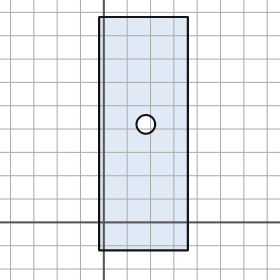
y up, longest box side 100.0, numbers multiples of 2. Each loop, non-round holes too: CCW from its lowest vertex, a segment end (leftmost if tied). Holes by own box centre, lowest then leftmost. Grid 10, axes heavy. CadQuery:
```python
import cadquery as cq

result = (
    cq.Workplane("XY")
    .moveTo(-2.0, -12.0)
    .lineTo(36.0, -12.0)
    .lineTo(36.0, 88.0)
    .lineTo(-2.0, 88.0)
    .close()
    .moveTo(18.0, 42.0)
    .circle(4.0)
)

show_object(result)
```